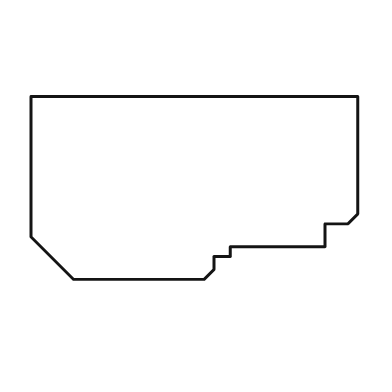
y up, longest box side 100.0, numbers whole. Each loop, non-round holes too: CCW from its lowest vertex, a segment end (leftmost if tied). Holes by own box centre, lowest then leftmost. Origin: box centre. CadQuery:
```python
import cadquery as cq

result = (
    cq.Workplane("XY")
    .moveTo(-37.0, -28.0)
    .lineTo(3.0, -28.0)
    .lineTo(6.0, -25.0)
    .lineTo(6.0, -21.0)
    .lineTo(11.0, -21.0)
    .lineTo(11.0, -18.0)
    .lineTo(40.0, -18.0)
    .lineTo(40.0, -11.0)
    .lineTo(47.0, -11.0)
    .lineTo(50.0, -8.0)
    .lineTo(50.0, 28.0)
    .lineTo(-50.0, 28.0)
    .lineTo(-50.0, -15.0)
    .close()
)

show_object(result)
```